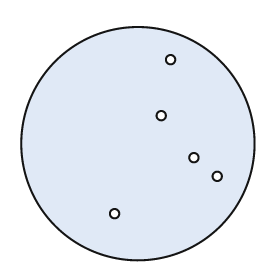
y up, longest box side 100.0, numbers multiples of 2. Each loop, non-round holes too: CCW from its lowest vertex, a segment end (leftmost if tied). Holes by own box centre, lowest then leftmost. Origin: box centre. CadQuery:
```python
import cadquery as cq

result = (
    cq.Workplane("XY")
    .moveTo(0.0, 0.0)
    .circle(50.0)
    .moveTo(-10.0, -30.0)
    .circle(2.0)
    .moveTo(34.0, -14.0)
    .circle(2.0)
    .moveTo(24.0, -6.0)
    .circle(2.0)
    .moveTo(10.0, 12.0)
    .circle(2.0)
    .moveTo(14.0, 36.0)
    .circle(2.0)
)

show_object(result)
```